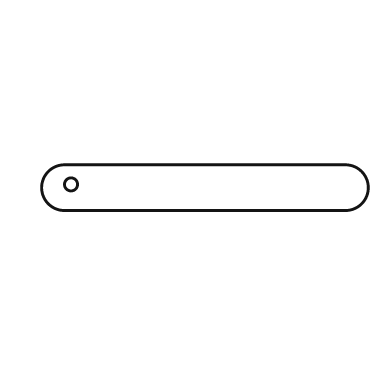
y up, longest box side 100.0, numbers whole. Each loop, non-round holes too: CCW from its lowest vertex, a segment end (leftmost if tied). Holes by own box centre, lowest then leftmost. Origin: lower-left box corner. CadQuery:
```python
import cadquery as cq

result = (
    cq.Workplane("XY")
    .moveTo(7.0, 0.0)
    .lineTo(93.0, 0.0)
    .threePointArc((100.0, 7.0), (93.0, 14.0))
    .lineTo(7.0, 14.0)
    .threePointArc((0.0, 7.0), (7.0, 0.0))
    .close()
    .moveTo(9.0, 8.0)
    .circle(2.0)
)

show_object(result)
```